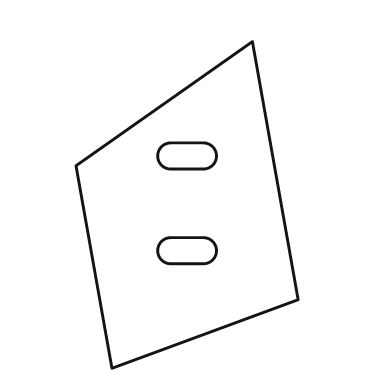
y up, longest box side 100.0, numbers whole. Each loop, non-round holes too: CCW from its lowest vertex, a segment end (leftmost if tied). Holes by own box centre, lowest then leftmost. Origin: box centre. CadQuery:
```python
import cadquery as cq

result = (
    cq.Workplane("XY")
    .moveTo(-23.0, -50.0)
    .lineTo(34.0, -29.0)
    .lineTo(20.0, 50.0)
    .lineTo(-34.0, 12.0)
    .close()
    .moveTo(-5.0, -18.0)
    .lineTo(5.0, -18.0)
    .threePointArc((9.0, -14.0), (5.0, -10.0))
    .lineTo(-5.0, -10.0)
    .threePointArc((-9.0, -14.0), (-5.0, -18.0))
    .close()
    .moveTo(-5.0, 11.0)
    .lineTo(5.0, 11.0)
    .threePointArc((9.0, 15.0), (5.0, 19.0))
    .lineTo(-5.0, 19.0)
    .threePointArc((-9.0, 15.0), (-5.0, 11.0))
    .close()
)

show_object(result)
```